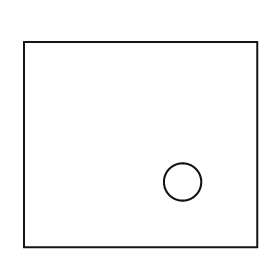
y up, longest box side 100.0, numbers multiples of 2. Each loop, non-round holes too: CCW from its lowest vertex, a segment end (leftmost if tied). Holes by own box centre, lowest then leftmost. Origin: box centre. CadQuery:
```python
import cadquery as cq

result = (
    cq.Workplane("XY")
    .moveTo(-50.0, -44.0)
    .lineTo(50.0, -44.0)
    .lineTo(50.0, 44.0)
    .lineTo(-50.0, 44.0)
    .close()
    .moveTo(18.0, -16.0)
    .circle(8.0)
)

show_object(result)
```